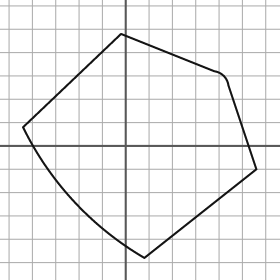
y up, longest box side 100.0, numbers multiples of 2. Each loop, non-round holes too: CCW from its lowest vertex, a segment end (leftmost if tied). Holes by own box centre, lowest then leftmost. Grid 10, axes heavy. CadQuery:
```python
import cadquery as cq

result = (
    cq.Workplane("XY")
    .moveTo(8.0, -48.0)
    .lineTo(56.0, -10.0)
    .lineTo(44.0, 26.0)
    .threePointArc((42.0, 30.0), (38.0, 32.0))
    .lineTo(-2.0, 48.0)
    .lineTo(-44.0, 8.0)
    .threePointArc((-22.0, -24.0), (8.0, -48.0))
    .close()
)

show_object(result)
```